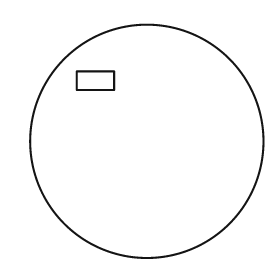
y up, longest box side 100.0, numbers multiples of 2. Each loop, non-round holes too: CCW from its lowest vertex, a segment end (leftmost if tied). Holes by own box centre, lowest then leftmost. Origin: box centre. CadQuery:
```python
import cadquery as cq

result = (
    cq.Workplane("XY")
    .moveTo(0.0, 0.0)
    .circle(50.0)
    .moveTo(-30.0, 22.0)
    .lineTo(-14.0, 22.0)
    .lineTo(-14.0, 30.0)
    .lineTo(-30.0, 30.0)
    .close()
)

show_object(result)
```